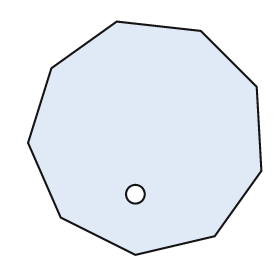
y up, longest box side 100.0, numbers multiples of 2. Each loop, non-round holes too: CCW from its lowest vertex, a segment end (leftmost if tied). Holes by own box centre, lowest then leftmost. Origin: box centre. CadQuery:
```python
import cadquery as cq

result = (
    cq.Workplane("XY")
    .moveTo(-4.0, -50.0)
    .lineTo(30.0, -42.0)
    .lineTo(50.0, -14.0)
    .lineTo(48.0, 22.0)
    .lineTo(24.0, 46.0)
    .lineTo(-12.0, 50.0)
    .lineTo(-40.0, 30.0)
    .lineTo(-50.0, -2.0)
    .lineTo(-36.0, -34.0)
    .close()
    .moveTo(-4.0, -24.0)
    .circle(4.0)
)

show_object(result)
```